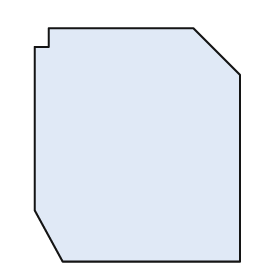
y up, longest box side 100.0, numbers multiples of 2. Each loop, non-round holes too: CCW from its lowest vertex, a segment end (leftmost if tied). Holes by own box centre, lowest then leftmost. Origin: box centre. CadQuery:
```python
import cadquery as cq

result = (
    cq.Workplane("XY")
    .moveTo(-32.0, -50.0)
    .lineTo(44.0, -50.0)
    .lineTo(44.0, 30.0)
    .lineTo(24.0, 50.0)
    .lineTo(-38.0, 50.0)
    .lineTo(-38.0, 42.0)
    .lineTo(-44.0, 42.0)
    .lineTo(-44.0, -28.0)
    .close()
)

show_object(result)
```